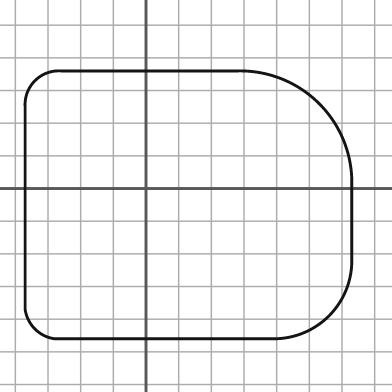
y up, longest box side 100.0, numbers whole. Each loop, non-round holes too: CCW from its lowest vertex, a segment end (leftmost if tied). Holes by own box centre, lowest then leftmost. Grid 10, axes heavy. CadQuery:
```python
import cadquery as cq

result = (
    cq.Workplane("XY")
    .moveTo(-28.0, -46.0)
    .lineTo(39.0, -46.0)
    .threePointArc((56.0, -39.0), (63.0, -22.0))
    .lineTo(63.0, 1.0)
    .threePointArc((53.0, 26.0), (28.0, 36.0))
    .lineTo(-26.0, 36.0)
    .threePointArc((-34.0, 33.0), (-37.0, 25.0))
    .lineTo(-37.0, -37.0)
    .threePointArc((-34.0, -43.0), (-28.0, -46.0))
    .close()
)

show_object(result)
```